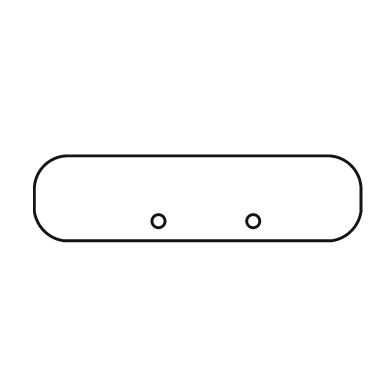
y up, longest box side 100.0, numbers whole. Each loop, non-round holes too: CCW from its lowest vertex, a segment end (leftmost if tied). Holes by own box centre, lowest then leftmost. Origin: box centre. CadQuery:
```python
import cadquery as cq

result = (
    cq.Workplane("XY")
    .moveTo(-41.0, -13.0)
    .lineTo(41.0, -13.0)
    .threePointArc((47.0, -10.0), (50.0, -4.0))
    .lineTo(50.0, 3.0)
    .threePointArc((47.0, 10.0), (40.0, 13.0))
    .lineTo(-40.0, 13.0)
    .threePointArc((-47.0, 10.0), (-50.0, 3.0))
    .lineTo(-50.0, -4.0)
    .threePointArc((-47.0, -10.0), (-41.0, -13.0))
    .close()
    .moveTo(-12.0, -7.0)
    .circle(2.0)
    .moveTo(17.0, -7.0)
    .circle(2.0)
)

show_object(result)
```